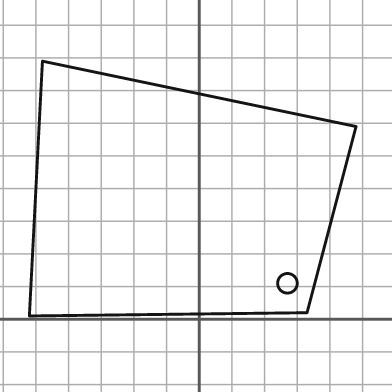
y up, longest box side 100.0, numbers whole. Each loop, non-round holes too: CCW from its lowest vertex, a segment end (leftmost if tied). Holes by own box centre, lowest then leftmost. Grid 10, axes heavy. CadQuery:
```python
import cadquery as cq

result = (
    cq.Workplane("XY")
    .moveTo(-52.0, 1.0)
    .lineTo(33.0, 2.0)
    .lineTo(48.0, 59.0)
    .lineTo(-48.0, 79.0)
    .close()
    .moveTo(27.0, 11.0)
    .circle(3.0)
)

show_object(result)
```